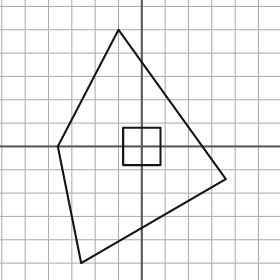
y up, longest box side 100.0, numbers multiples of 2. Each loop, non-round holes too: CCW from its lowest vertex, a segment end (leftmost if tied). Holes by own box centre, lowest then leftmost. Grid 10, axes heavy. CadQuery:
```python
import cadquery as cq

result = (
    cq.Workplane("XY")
    .moveTo(-26.0, -50.0)
    .lineTo(36.0, -14.0)
    .lineTo(-10.0, 50.0)
    .lineTo(-36.0, 0.0)
    .close()
    .moveTo(-8.0, -8.0)
    .lineTo(8.0, -8.0)
    .lineTo(8.0, 8.0)
    .lineTo(-8.0, 8.0)
    .close()
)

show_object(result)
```